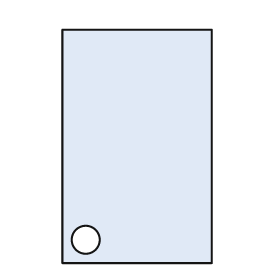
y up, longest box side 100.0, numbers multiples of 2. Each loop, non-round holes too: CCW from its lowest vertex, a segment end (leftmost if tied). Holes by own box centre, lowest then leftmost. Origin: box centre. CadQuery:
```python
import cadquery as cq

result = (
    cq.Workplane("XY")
    .moveTo(-32.0, -50.0)
    .lineTo(32.0, -50.0)
    .lineTo(32.0, 50.0)
    .lineTo(-32.0, 50.0)
    .close()
    .moveTo(-22.0, -40.0)
    .circle(6.0)
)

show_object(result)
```